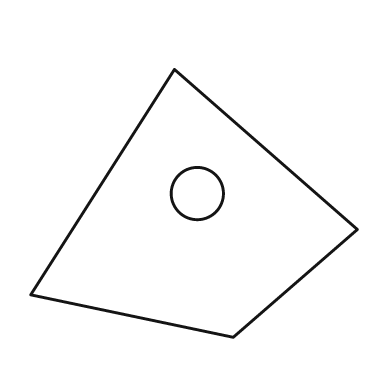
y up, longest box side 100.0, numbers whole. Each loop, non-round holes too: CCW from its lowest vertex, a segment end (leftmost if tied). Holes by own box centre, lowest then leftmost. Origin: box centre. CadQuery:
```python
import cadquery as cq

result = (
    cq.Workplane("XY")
    .moveTo(12.0, -41.0)
    .lineTo(50.0, -8.0)
    .lineTo(-6.0, 41.0)
    .lineTo(-50.0, -28.0)
    .close()
    .moveTo(1.0, 3.0)
    .circle(8.0)
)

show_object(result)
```